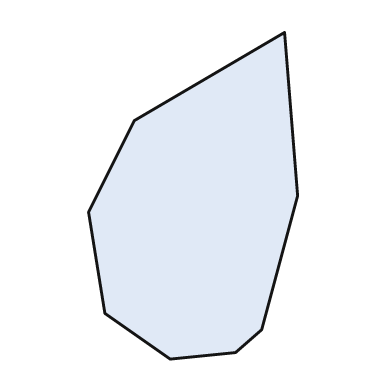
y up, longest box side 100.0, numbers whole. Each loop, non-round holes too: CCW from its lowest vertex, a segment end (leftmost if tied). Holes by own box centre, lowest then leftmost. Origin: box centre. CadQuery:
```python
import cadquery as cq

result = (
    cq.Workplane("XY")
    .moveTo(-7.0, -50.0)
    .lineTo(13.0, -48.0)
    .lineTo(21.0, -41.0)
    .lineTo(32.0, 0.0)
    .lineTo(28.0, 50.0)
    .lineTo(-18.0, 23.0)
    .lineTo(-32.0, -5.0)
    .lineTo(-27.0, -36.0)
    .close()
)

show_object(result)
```